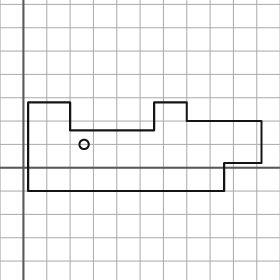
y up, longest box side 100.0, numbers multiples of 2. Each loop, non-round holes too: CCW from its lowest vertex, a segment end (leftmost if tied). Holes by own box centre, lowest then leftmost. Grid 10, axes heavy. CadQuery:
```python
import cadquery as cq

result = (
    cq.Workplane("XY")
    .moveTo(2.0, -10.0)
    .lineTo(86.0, -10.0)
    .lineTo(86.0, 2.0)
    .lineTo(102.0, 2.0)
    .lineTo(102.0, 20.0)
    .lineTo(70.0, 20.0)
    .lineTo(70.0, 28.0)
    .lineTo(56.0, 28.0)
    .lineTo(56.0, 16.0)
    .lineTo(20.0, 16.0)
    .lineTo(20.0, 28.0)
    .lineTo(2.0, 28.0)
    .close()
    .moveTo(26.0, 10.0)
    .circle(2.0)
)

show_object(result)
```